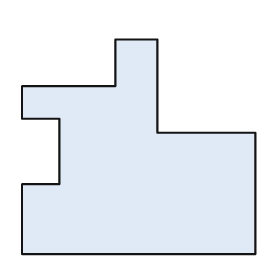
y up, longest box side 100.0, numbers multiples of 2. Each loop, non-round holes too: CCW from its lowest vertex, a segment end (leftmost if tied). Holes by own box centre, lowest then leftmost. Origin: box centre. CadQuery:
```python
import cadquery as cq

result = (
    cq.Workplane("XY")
    .moveTo(-50.0, -46.0)
    .lineTo(50.0, -46.0)
    .lineTo(50.0, 6.0)
    .lineTo(8.0, 6.0)
    .lineTo(8.0, 46.0)
    .lineTo(-10.0, 46.0)
    .lineTo(-10.0, 26.0)
    .lineTo(-50.0, 26.0)
    .lineTo(-50.0, 12.0)
    .lineTo(-34.0, 12.0)
    .lineTo(-34.0, -16.0)
    .lineTo(-50.0, -16.0)
    .close()
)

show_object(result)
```